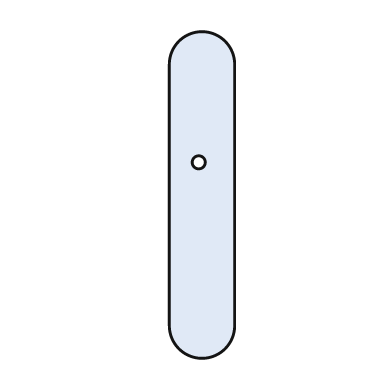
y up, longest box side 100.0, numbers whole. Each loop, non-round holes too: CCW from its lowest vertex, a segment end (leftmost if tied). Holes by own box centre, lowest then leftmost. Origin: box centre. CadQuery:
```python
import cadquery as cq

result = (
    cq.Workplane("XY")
    .moveTo(-10.0, -40.0)
    .threePointArc((0.0, -50.0), (10.0, -40.0))
    .lineTo(10.0, 40.0)
    .threePointArc((0.0, 50.0), (-10.0, 40.0))
    .close()
    .moveTo(-1.0, 10.0)
    .circle(2.0)
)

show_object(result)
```